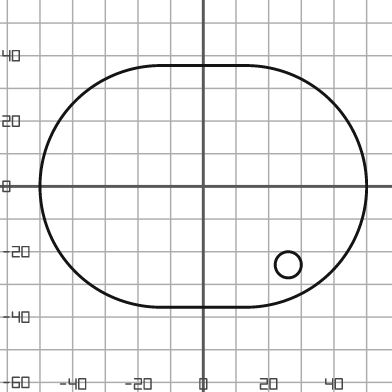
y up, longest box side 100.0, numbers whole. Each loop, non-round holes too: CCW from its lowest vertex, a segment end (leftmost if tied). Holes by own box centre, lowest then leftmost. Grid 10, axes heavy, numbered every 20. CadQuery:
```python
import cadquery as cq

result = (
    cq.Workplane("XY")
    .moveTo(-13.0, -37.0)
    .lineTo(13.0, -37.0)
    .threePointArc((50.0, 0.0), (13.0, 37.0))
    .lineTo(-13.0, 37.0)
    .threePointArc((-50.0, 0.0), (-13.0, -37.0))
    .close()
    .moveTo(26.0, -24.0)
    .circle(4.0)
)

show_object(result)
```